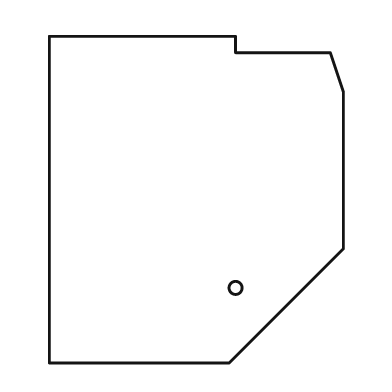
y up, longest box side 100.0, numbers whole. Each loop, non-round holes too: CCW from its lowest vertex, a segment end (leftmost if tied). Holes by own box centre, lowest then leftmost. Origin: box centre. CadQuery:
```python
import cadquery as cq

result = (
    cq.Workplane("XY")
    .moveTo(-45.0, -50.0)
    .lineTo(10.0, -50.0)
    .lineTo(45.0, -15.0)
    .lineTo(45.0, 33.0)
    .lineTo(41.0, 45.0)
    .lineTo(12.0, 45.0)
    .lineTo(12.0, 50.0)
    .lineTo(-45.0, 50.0)
    .close()
    .moveTo(12.0, -27.0)
    .circle(2.0)
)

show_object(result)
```